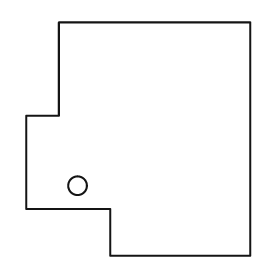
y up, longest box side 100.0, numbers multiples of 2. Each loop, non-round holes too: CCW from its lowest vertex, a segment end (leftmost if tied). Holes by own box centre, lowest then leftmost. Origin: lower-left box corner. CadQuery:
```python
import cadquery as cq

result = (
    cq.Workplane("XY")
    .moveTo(36.0, 0.0)
    .lineTo(96.0, 0.0)
    .lineTo(96.0, 100.0)
    .lineTo(14.0, 100.0)
    .lineTo(14.0, 60.0)
    .lineTo(0.0, 60.0)
    .lineTo(0.0, 20.0)
    .lineTo(36.0, 20.0)
    .close()
    .moveTo(22.0, 30.0)
    .circle(4.0)
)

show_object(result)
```